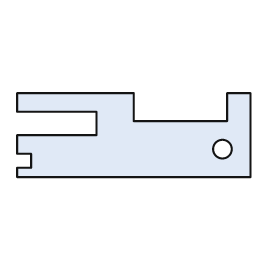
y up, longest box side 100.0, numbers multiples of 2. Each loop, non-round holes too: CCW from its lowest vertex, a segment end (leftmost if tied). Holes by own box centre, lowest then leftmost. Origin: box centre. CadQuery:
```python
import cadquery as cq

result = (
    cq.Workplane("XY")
    .moveTo(-50.0, -18.0)
    .lineTo(50.0, -18.0)
    .lineTo(50.0, 18.0)
    .lineTo(40.0, 18.0)
    .lineTo(40.0, 6.0)
    .lineTo(0.0, 6.0)
    .lineTo(0.0, 18.0)
    .lineTo(-50.0, 18.0)
    .lineTo(-50.0, 10.0)
    .lineTo(-16.0, 10.0)
    .lineTo(-16.0, 0.0)
    .lineTo(-50.0, 0.0)
    .lineTo(-50.0, -8.0)
    .lineTo(-44.0, -8.0)
    .lineTo(-44.0, -14.0)
    .lineTo(-50.0, -14.0)
    .close()
    .moveTo(38.0, -6.0)
    .circle(4.0)
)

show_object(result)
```